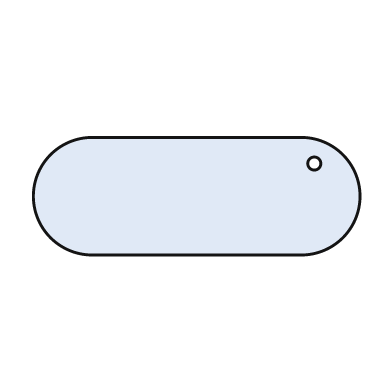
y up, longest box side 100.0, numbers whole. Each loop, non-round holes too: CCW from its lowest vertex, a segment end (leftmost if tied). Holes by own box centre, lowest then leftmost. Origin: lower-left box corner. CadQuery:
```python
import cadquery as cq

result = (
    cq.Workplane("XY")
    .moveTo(18.0, 0.0)
    .lineTo(82.0, 0.0)
    .threePointArc((100.0, 18.0), (82.0, 36.0))
    .lineTo(18.0, 36.0)
    .threePointArc((0.0, 18.0), (18.0, 0.0))
    .close()
    .moveTo(86.0, 28.0)
    .circle(2.0)
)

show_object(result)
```